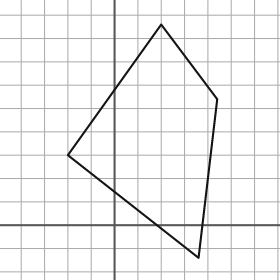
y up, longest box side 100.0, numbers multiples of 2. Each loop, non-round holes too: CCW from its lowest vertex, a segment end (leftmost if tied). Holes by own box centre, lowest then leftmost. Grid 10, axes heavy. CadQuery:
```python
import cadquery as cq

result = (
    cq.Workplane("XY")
    .moveTo(36.0, -14.0)
    .lineTo(44.0, 54.0)
    .lineTo(20.0, 86.0)
    .lineTo(-20.0, 30.0)
    .close()
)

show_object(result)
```